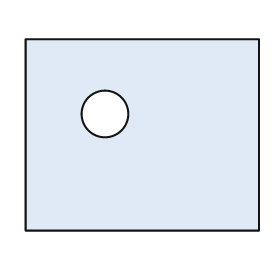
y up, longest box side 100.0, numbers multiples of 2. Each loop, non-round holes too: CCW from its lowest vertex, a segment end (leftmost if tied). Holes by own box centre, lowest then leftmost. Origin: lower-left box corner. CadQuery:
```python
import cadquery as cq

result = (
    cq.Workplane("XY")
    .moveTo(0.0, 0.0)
    .lineTo(100.0, 0.0)
    .lineTo(100.0, 82.0)
    .lineTo(0.0, 82.0)
    .close()
    .moveTo(34.0, 50.0)
    .circle(10.0)
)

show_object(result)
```